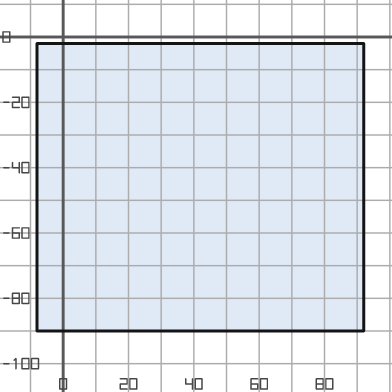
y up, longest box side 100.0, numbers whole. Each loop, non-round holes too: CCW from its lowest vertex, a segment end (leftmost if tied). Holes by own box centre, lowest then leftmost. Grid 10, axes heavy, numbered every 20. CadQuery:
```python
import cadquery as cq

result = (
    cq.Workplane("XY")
    .moveTo(-8.0, -90.0)
    .lineTo(92.0, -90.0)
    .lineTo(92.0, -2.0)
    .lineTo(-8.0, -2.0)
    .close()
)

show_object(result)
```